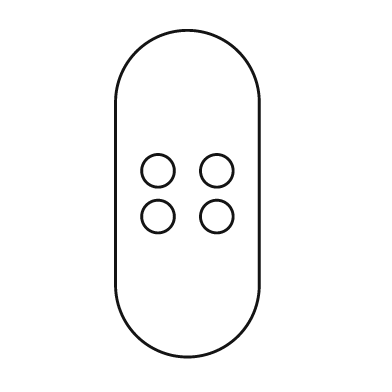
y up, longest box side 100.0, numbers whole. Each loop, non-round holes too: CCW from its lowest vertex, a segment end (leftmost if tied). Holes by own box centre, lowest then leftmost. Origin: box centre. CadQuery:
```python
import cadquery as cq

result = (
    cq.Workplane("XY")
    .moveTo(-22.0, -28.0)
    .threePointArc((0.0, -50.0), (22.0, -28.0))
    .lineTo(22.0, 28.0)
    .threePointArc((0.0, 50.0), (-22.0, 28.0))
    .close()
    .moveTo(-9.0, -7.0)
    .circle(5.0)
    .moveTo(9.0, -7.0)
    .circle(5.0)
    .moveTo(-9.0, 7.0)
    .circle(5.0)
    .moveTo(9.0, 7.0)
    .circle(5.0)
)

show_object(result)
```